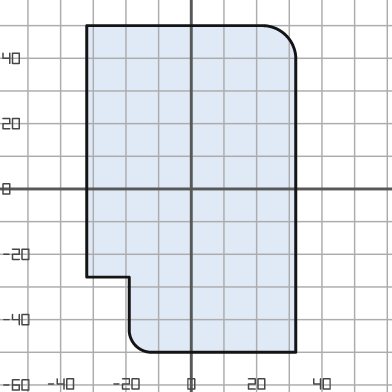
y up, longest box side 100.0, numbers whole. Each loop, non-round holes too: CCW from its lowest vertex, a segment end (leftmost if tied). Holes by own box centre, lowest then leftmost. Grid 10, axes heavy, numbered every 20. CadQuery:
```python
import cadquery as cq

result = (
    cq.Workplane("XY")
    .moveTo(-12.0, -50.0)
    .lineTo(32.0, -50.0)
    .lineTo(32.0, 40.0)
    .threePointArc((29.0, 47.0), (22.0, 50.0))
    .lineTo(-32.0, 50.0)
    .lineTo(-32.0, -27.0)
    .lineTo(-19.0, -27.0)
    .lineTo(-19.0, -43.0)
    .threePointArc((-17.0, -48.0), (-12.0, -50.0))
    .close()
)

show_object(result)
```